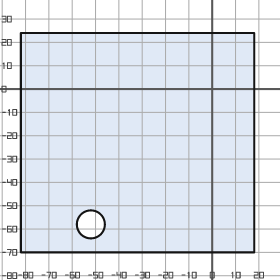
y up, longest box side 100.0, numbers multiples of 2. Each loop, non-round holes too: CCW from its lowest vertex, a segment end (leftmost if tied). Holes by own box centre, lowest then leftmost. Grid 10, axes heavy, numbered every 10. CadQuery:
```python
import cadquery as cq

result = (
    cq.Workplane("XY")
    .moveTo(-82.0, -70.0)
    .lineTo(18.0, -70.0)
    .lineTo(18.0, 24.0)
    .lineTo(-82.0, 24.0)
    .close()
    .moveTo(-52.0, -58.0)
    .circle(6.0)
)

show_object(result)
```